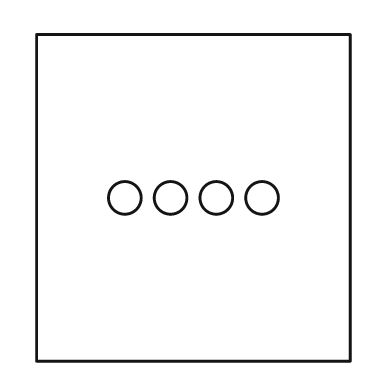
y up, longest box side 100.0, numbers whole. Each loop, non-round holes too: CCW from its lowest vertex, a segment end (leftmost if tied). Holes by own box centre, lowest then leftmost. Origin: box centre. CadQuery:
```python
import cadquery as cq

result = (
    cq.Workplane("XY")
    .moveTo(-48.0, -50.0)
    .lineTo(48.0, -50.0)
    .lineTo(48.0, 50.0)
    .lineTo(-48.0, 50.0)
    .close()
    .moveTo(-21.0, 0.0)
    .circle(5.0)
    .moveTo(-7.0, 0.0)
    .circle(5.0)
    .moveTo(7.0, 0.0)
    .circle(5.0)
    .moveTo(21.0, 0.0)
    .circle(5.0)
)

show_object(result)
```